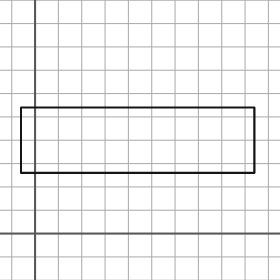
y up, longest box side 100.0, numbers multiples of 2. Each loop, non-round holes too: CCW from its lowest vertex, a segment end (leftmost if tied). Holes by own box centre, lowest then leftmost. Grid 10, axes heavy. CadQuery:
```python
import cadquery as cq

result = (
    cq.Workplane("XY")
    .moveTo(-6.0, 26.0)
    .lineTo(94.0, 26.0)
    .lineTo(94.0, 54.0)
    .lineTo(-6.0, 54.0)
    .close()
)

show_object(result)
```